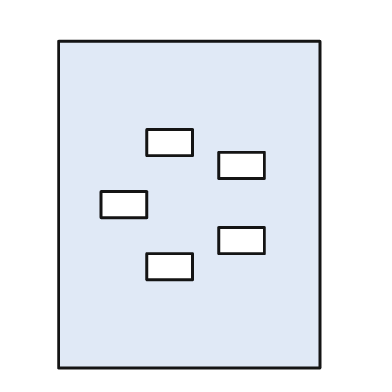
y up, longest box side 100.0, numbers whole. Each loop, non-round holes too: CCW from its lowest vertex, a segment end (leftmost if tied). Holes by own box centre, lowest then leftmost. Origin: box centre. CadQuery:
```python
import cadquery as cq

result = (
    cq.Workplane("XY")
    .moveTo(-40.0, -50.0)
    .lineTo(40.0, -50.0)
    .lineTo(40.0, 50.0)
    .lineTo(-40.0, 50.0)
    .close()
    .moveTo(-13.0, -23.0)
    .lineTo(1.0, -23.0)
    .lineTo(1.0, -15.0)
    .lineTo(-13.0, -15.0)
    .close()
    .moveTo(9.0, -15.0)
    .lineTo(23.0, -15.0)
    .lineTo(23.0, -7.0)
    .lineTo(9.0, -7.0)
    .close()
    .moveTo(-27.0, -4.0)
    .lineTo(-13.0, -4.0)
    .lineTo(-13.0, 4.0)
    .lineTo(-27.0, 4.0)
    .close()
    .moveTo(9.0, 8.0)
    .lineTo(23.0, 8.0)
    .lineTo(23.0, 16.0)
    .lineTo(9.0, 16.0)
    .close()
    .moveTo(-13.0, 15.0)
    .lineTo(1.0, 15.0)
    .lineTo(1.0, 23.0)
    .lineTo(-13.0, 23.0)
    .close()
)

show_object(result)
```